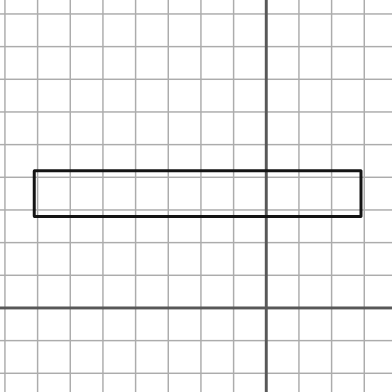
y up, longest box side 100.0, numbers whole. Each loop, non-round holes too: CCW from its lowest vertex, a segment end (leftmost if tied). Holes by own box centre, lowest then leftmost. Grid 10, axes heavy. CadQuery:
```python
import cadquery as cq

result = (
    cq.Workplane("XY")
    .moveTo(-71.0, 28.0)
    .lineTo(29.0, 28.0)
    .lineTo(29.0, 42.0)
    .lineTo(-71.0, 42.0)
    .close()
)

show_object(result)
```